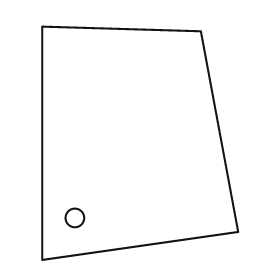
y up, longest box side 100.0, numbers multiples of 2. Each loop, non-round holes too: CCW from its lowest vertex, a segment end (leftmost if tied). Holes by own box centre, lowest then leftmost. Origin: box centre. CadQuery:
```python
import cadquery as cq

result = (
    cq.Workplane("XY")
    .moveTo(-42.0, -50.0)
    .lineTo(42.0, -38.0)
    .lineTo(26.0, 48.0)
    .lineTo(-42.0, 50.0)
    .close()
    .moveTo(-28.0, -32.0)
    .circle(4.0)
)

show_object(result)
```